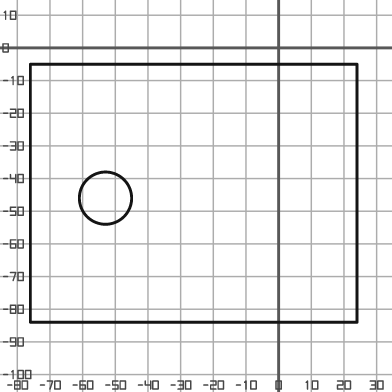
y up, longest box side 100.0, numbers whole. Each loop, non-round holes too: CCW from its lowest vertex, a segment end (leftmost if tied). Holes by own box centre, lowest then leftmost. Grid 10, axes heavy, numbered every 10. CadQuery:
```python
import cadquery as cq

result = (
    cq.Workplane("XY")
    .moveTo(-76.0, -84.0)
    .lineTo(24.0, -84.0)
    .lineTo(24.0, -5.0)
    .lineTo(-76.0, -5.0)
    .close()
    .moveTo(-53.0, -46.0)
    .circle(8.0)
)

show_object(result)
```